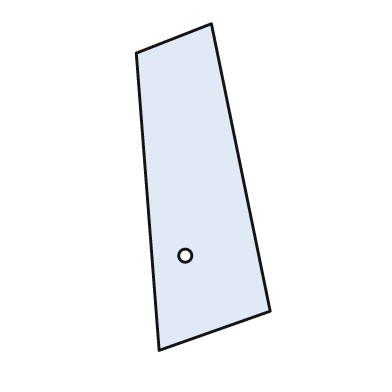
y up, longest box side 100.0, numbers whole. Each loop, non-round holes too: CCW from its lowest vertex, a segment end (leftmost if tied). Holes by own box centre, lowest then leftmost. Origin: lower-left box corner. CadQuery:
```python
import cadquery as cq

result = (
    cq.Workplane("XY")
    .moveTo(7.0, 0.0)
    .lineTo(41.0, 12.0)
    .lineTo(23.0, 100.0)
    .lineTo(0.0, 91.0)
    .close()
    .moveTo(15.0, 29.0)
    .circle(2.0)
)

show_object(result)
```